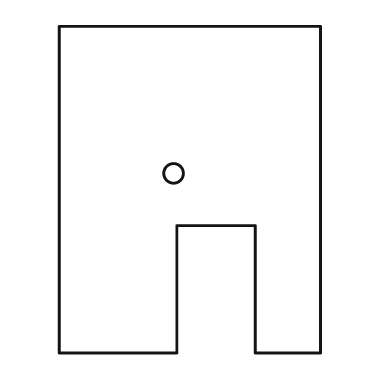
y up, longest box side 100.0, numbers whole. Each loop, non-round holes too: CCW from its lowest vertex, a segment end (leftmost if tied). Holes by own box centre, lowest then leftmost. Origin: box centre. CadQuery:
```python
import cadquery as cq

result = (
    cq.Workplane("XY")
    .moveTo(-40.0, -50.0)
    .lineTo(-4.0, -50.0)
    .lineTo(-4.0, -11.0)
    .lineTo(20.0, -11.0)
    .lineTo(20.0, -50.0)
    .lineTo(40.0, -50.0)
    .lineTo(40.0, 50.0)
    .lineTo(-40.0, 50.0)
    .close()
    .moveTo(-5.0, 5.0)
    .circle(3.0)
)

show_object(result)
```